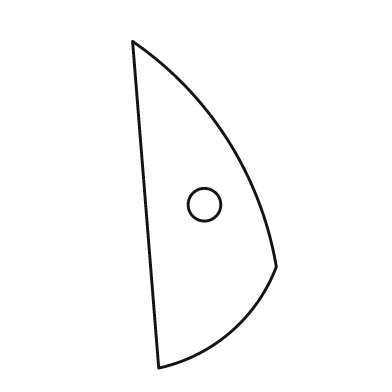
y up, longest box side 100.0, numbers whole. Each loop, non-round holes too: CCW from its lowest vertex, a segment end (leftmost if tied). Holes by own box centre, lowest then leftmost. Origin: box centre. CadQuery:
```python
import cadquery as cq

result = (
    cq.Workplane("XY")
    .moveTo(-14.0, -50.0)
    .threePointArc((8.0, -39.0), (22.0, -19.0))
    .threePointArc((7.0, 20.0), (-22.0, 50.0))
    .close()
    .moveTo(0.0, 0.0)
    .circle(5.0)
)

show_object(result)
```